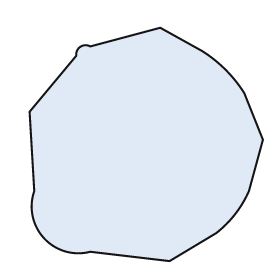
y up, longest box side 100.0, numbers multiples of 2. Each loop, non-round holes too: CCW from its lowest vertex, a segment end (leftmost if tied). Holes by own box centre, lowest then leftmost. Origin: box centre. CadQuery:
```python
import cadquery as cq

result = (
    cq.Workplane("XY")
    .moveTo(10.0, -50.0)
    .lineTo(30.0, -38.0)
    .threePointArc((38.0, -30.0), (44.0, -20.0))
    .lineTo(50.0, 2.0)
    .lineTo(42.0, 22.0)
    .threePointArc((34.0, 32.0), (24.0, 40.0))
    .lineTo(6.0, 50.0)
    .lineTo(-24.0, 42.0)
    .threePointArc((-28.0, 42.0), (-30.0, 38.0))
    .lineTo(-50.0, 14.0)
    .lineTo(-48.0, -20.0)
    .threePointArc((-44.0, -40.0), (-24.0, -46.0))
    .close()
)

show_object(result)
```